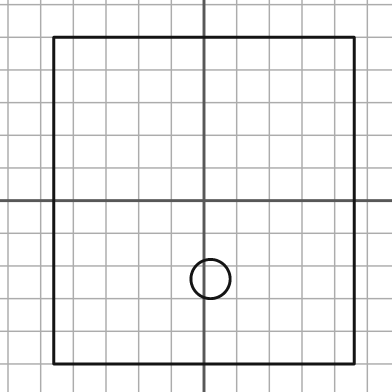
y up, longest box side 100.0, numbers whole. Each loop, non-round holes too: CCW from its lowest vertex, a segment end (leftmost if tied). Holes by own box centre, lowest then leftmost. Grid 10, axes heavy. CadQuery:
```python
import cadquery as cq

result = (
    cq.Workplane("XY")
    .moveTo(-46.0, -50.0)
    .lineTo(46.0, -50.0)
    .lineTo(46.0, 50.0)
    .lineTo(-46.0, 50.0)
    .close()
    .moveTo(2.0, -24.0)
    .circle(6.0)
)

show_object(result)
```